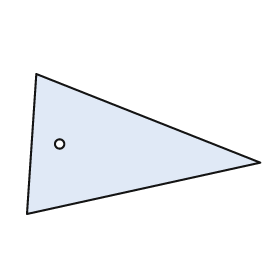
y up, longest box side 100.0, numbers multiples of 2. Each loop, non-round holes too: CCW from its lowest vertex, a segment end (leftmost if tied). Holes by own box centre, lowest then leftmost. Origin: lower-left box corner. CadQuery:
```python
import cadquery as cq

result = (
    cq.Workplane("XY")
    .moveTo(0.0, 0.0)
    .lineTo(100.0, 22.0)
    .lineTo(4.0, 60.0)
    .close()
    .moveTo(14.0, 30.0)
    .circle(2.0)
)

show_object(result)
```